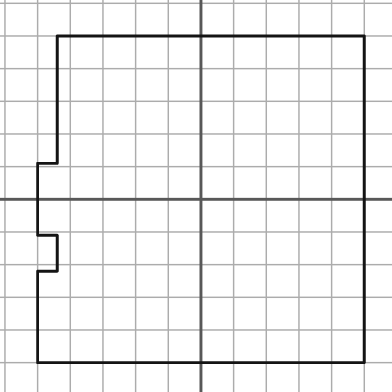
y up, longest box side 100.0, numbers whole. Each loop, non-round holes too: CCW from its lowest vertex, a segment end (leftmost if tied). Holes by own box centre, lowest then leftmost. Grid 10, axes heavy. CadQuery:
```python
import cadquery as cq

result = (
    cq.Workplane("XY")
    .moveTo(-50.0, -50.0)
    .lineTo(50.0, -50.0)
    .lineTo(50.0, 50.0)
    .lineTo(-44.0, 50.0)
    .lineTo(-44.0, 11.0)
    .lineTo(-50.0, 11.0)
    .lineTo(-50.0, -11.0)
    .lineTo(-44.0, -11.0)
    .lineTo(-44.0, -22.0)
    .lineTo(-50.0, -22.0)
    .close()
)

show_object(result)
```